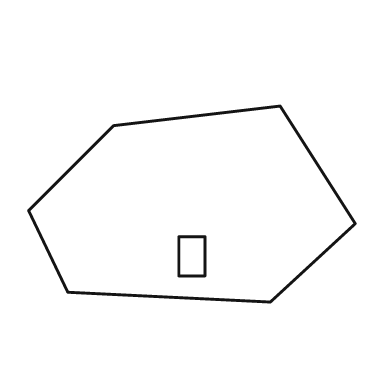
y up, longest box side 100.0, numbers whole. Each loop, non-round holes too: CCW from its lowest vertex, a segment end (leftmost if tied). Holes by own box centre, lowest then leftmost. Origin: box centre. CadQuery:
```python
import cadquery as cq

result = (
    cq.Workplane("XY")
    .moveTo(24.0, -30.0)
    .lineTo(50.0, -6.0)
    .lineTo(27.0, 30.0)
    .lineTo(-24.0, 24.0)
    .lineTo(-50.0, -2.0)
    .lineTo(-38.0, -27.0)
    .close()
    .moveTo(-4.0, -22.0)
    .lineTo(4.0, -22.0)
    .lineTo(4.0, -10.0)
    .lineTo(-4.0, -10.0)
    .close()
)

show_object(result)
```